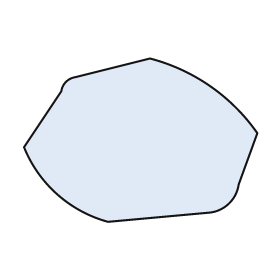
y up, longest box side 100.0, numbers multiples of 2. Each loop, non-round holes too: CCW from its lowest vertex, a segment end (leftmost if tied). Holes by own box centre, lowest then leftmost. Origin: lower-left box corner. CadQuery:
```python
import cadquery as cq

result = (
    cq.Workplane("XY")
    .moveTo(36.0, 0.0)
    .lineTo(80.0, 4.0)
    .threePointArc((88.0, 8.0), (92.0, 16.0))
    .lineTo(100.0, 38.0)
    .threePointArc((80.0, 58.0), (54.0, 70.0))
    .lineTo(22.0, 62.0)
    .threePointArc((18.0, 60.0), (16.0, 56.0))
    .lineTo(0.0, 32.0)
    .threePointArc((14.0, 12.0), (36.0, 0.0))
    .close()
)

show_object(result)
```